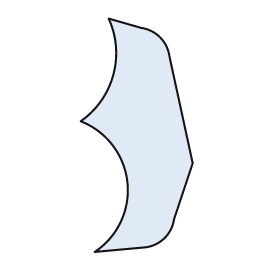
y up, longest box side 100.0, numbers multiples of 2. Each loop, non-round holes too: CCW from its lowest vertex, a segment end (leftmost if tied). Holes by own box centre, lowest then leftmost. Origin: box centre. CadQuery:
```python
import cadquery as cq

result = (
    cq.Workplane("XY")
    .moveTo(-18.0, -50.0)
    .lineTo(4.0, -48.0)
    .threePointArc((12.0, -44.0), (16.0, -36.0))
    .lineTo(24.0, -12.0)
    .lineTo(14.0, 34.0)
    .threePointArc((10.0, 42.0), (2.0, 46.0))
    .lineTo(-12.0, 50.0)
    .threePointArc((-10.0, 26.0), (-24.0, 6.0))
    .threePointArc((-4.0, -20.0), (-18.0, -50.0))
    .close()
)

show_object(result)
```